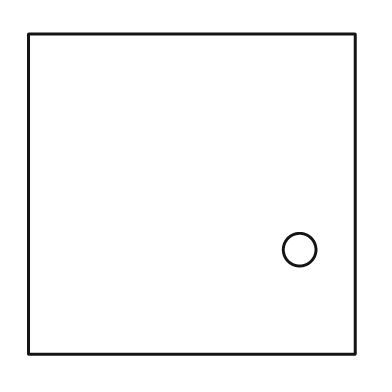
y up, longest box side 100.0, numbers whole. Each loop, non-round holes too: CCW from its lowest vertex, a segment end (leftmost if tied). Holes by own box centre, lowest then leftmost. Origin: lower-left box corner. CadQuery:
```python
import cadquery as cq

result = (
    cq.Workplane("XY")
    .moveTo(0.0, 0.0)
    .lineTo(100.0, 0.0)
    .lineTo(100.0, 98.0)
    .lineTo(0.0, 98.0)
    .close()
    .moveTo(83.0, 32.0)
    .circle(5.0)
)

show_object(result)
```